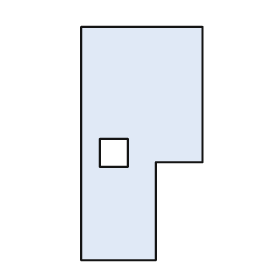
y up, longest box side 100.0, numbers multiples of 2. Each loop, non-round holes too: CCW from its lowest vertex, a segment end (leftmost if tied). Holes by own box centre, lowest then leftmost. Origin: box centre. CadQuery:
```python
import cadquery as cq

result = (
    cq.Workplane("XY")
    .moveTo(-26.0, -50.0)
    .lineTo(6.0, -50.0)
    .lineTo(6.0, -8.0)
    .lineTo(26.0, -8.0)
    .lineTo(26.0, 50.0)
    .lineTo(-26.0, 50.0)
    .close()
    .moveTo(-18.0, -10.0)
    .lineTo(-6.0, -10.0)
    .lineTo(-6.0, 2.0)
    .lineTo(-18.0, 2.0)
    .close()
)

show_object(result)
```